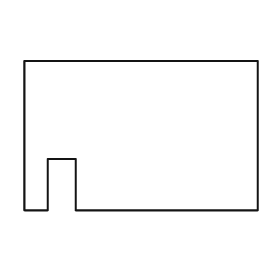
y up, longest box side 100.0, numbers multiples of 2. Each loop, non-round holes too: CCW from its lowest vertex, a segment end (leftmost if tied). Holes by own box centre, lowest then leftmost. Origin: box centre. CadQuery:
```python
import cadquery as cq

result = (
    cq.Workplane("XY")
    .moveTo(-50.0, -32.0)
    .lineTo(-40.0, -32.0)
    .lineTo(-40.0, -10.0)
    .lineTo(-28.0, -10.0)
    .lineTo(-28.0, -32.0)
    .lineTo(50.0, -32.0)
    .lineTo(50.0, 32.0)
    .lineTo(-50.0, 32.0)
    .close()
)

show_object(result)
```